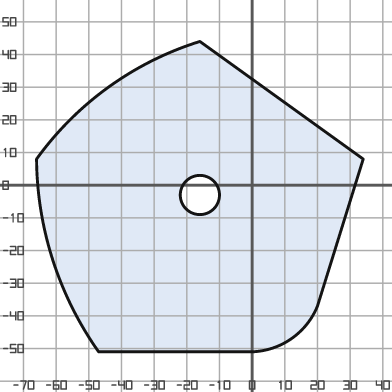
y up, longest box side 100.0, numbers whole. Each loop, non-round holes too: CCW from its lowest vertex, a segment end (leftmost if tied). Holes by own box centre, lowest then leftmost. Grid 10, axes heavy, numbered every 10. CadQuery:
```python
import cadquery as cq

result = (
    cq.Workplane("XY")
    .moveTo(-47.0, -51.0)
    .lineTo(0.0, -51.0)
    .threePointArc((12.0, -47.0), (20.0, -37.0))
    .lineTo(34.0, 8.0)
    .lineTo(-16.0, 44.0)
    .threePointArc((-44.0, 30.0), (-66.0, 8.0))
    .threePointArc((-61.0, -23.0), (-47.0, -51.0))
    .close()
    .moveTo(-16.0, -3.0)
    .circle(6.0)
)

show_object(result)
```